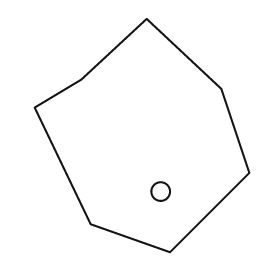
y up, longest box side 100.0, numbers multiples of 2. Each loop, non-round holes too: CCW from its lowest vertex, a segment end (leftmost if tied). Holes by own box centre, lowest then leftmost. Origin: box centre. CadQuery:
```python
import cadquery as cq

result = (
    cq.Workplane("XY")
    .moveTo(12.0, -50.0)
    .lineTo(46.0, -16.0)
    .lineTo(34.0, 20.0)
    .lineTo(2.0, 50.0)
    .lineTo(-26.0, 24.0)
    .lineTo(-46.0, 12.0)
    .lineTo(-22.0, -38.0)
    .close()
    .moveTo(8.0, -24.0)
    .circle(4.0)
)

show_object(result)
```